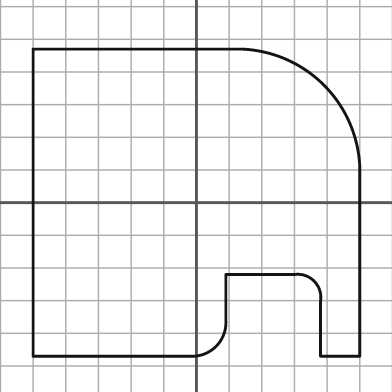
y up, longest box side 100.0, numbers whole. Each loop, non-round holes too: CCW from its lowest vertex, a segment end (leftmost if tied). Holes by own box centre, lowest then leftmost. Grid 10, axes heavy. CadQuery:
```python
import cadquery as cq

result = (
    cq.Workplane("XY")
    .moveTo(-50.0, -47.0)
    .lineTo(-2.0, -47.0)
    .threePointArc((6.0, -44.0), (9.0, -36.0))
    .lineTo(9.0, -22.0)
    .lineTo(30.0, -22.0)
    .threePointArc((36.0, -24.0), (38.0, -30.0))
    .lineTo(38.0, -47.0)
    .lineTo(50.0, -47.0)
    .lineTo(50.0, 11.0)
    .threePointArc((39.0, 36.0), (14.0, 47.0))
    .lineTo(-50.0, 47.0)
    .close()
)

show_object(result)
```